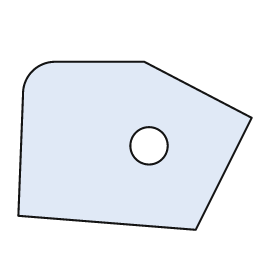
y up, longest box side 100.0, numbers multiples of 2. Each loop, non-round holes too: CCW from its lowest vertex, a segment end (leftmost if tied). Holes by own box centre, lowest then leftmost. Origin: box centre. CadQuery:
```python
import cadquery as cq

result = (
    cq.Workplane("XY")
    .moveTo(26.0, -36.0)
    .lineTo(50.0, 12.0)
    .lineTo(4.0, 36.0)
    .lineTo(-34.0, 36.0)
    .threePointArc((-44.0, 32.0), (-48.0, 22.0))
    .lineTo(-50.0, -30.0)
    .close()
    .moveTo(6.0, 0.0)
    .circle(8.0)
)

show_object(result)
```